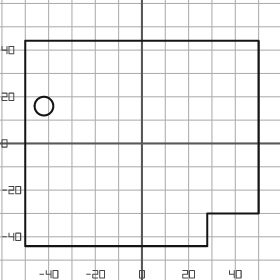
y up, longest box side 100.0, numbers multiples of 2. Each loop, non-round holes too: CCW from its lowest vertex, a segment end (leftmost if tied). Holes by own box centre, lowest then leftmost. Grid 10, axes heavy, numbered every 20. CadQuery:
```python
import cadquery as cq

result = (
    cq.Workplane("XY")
    .moveTo(-50.0, -44.0)
    .lineTo(28.0, -44.0)
    .lineTo(28.0, -30.0)
    .lineTo(50.0, -30.0)
    .lineTo(50.0, 44.0)
    .lineTo(-50.0, 44.0)
    .close()
    .moveTo(-42.0, 16.0)
    .circle(4.0)
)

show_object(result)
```